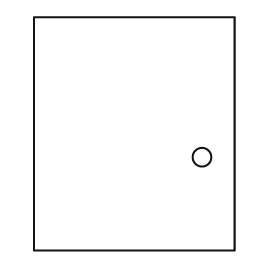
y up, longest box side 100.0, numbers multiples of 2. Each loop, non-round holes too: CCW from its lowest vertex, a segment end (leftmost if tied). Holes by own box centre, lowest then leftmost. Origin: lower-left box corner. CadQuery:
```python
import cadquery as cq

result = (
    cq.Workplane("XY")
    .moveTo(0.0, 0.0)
    .lineTo(86.0, 0.0)
    .lineTo(86.0, 100.0)
    .lineTo(0.0, 100.0)
    .close()
    .moveTo(72.0, 40.0)
    .circle(4.0)
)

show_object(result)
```